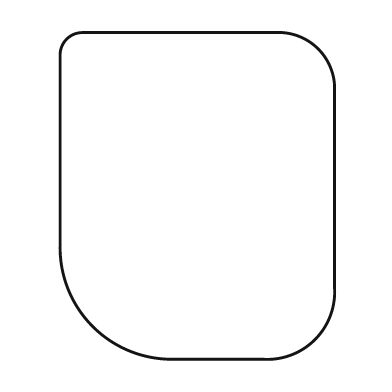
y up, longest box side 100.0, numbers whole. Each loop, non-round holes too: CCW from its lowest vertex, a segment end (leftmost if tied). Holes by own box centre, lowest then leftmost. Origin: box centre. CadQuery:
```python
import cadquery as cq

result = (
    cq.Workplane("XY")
    .moveTo(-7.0, -50.0)
    .lineTo(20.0, -50.0)
    .threePointArc((36.0, -44.0), (42.0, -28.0))
    .lineTo(42.0, 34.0)
    .threePointArc((37.0, 45.0), (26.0, 50.0))
    .lineTo(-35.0, 50.0)
    .threePointArc((-40.0, 48.0), (-42.0, 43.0))
    .lineTo(-42.0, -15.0)
    .threePointArc((-32.0, -40.0), (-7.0, -50.0))
    .close()
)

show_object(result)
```